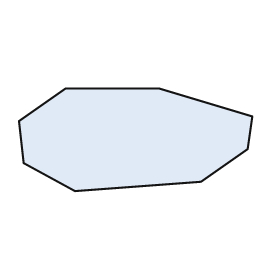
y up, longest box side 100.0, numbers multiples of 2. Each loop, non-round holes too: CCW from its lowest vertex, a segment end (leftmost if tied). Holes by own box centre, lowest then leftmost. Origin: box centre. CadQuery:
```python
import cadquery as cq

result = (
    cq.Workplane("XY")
    .moveTo(-26.0, -22.0)
    .lineTo(28.0, -18.0)
    .lineTo(48.0, -4.0)
    .lineTo(50.0, 10.0)
    .lineTo(10.0, 22.0)
    .lineTo(-30.0, 22.0)
    .lineTo(-50.0, 8.0)
    .lineTo(-48.0, -10.0)
    .close()
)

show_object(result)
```